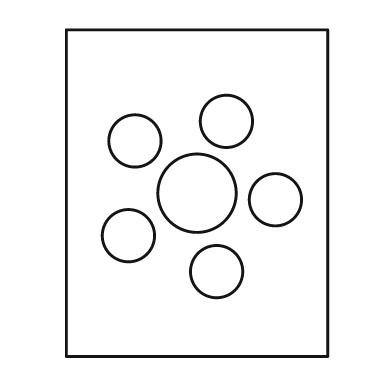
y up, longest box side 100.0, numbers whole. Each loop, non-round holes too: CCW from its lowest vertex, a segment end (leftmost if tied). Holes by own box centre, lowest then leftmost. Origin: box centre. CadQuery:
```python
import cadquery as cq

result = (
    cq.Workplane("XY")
    .moveTo(-40.0, -50.0)
    .lineTo(40.0, -50.0)
    .lineTo(40.0, 50.0)
    .lineTo(-40.0, 50.0)
    .close()
    .moveTo(6.0, -24.0)
    .circle(8.0)
    .moveTo(-21.0, -13.0)
    .circle(8.0)
    .moveTo(24.0, -2.0)
    .circle(8.0)
    .moveTo(0.0, 0.0)
    .circle(12.0)
    .moveTo(-19.0, 16.0)
    .circle(8.0)
    .moveTo(9.0, 22.0)
    .circle(8.0)
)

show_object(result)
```